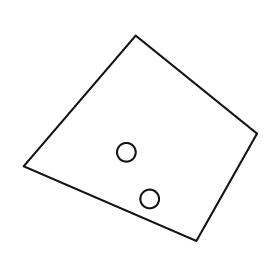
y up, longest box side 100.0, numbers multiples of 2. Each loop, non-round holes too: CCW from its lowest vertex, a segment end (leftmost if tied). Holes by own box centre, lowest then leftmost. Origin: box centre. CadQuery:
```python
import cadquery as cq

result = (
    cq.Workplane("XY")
    .moveTo(24.0, -44.0)
    .lineTo(50.0, 2.0)
    .lineTo(-2.0, 44.0)
    .lineTo(-50.0, -12.0)
    .close()
    .moveTo(4.0, -26.0)
    .circle(4.0)
    .moveTo(-6.0, -6.0)
    .circle(4.0)
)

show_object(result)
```